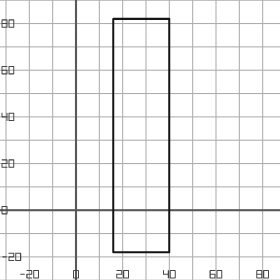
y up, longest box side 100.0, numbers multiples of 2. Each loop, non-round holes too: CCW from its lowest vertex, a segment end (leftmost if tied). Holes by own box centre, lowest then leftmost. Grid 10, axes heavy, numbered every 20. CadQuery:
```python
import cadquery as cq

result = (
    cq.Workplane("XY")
    .moveTo(16.0, -18.0)
    .lineTo(40.0, -18.0)
    .lineTo(40.0, 82.0)
    .lineTo(16.0, 82.0)
    .close()
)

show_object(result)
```